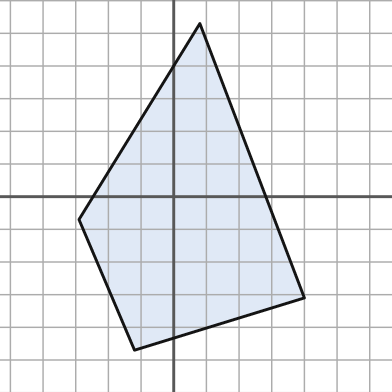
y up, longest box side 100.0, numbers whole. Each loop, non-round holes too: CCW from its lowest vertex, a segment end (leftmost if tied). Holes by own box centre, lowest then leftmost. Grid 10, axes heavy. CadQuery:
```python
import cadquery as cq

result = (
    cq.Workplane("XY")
    .moveTo(-12.0, -47.0)
    .lineTo(40.0, -31.0)
    .lineTo(8.0, 53.0)
    .lineTo(-29.0, -7.0)
    .close()
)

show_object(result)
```